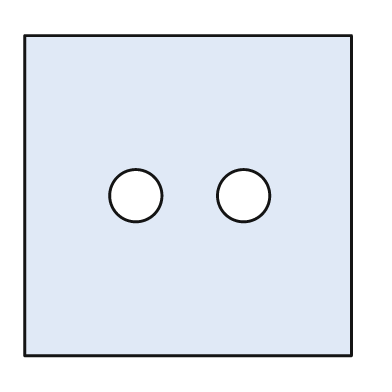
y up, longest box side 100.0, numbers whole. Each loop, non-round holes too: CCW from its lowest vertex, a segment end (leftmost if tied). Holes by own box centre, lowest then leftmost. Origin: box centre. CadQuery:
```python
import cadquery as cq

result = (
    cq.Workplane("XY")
    .moveTo(-50.0, -49.0)
    .lineTo(50.0, -49.0)
    .lineTo(50.0, 49.0)
    .lineTo(-50.0, 49.0)
    .close()
    .moveTo(-16.0, 0.0)
    .circle(8.0)
    .moveTo(17.0, 0.0)
    .circle(8.0)
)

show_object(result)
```